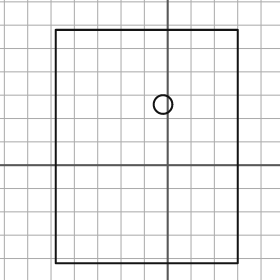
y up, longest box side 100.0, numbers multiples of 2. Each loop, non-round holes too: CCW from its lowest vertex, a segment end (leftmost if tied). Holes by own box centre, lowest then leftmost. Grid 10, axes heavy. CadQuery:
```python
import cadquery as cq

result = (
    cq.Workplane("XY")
    .moveTo(-48.0, -42.0)
    .lineTo(30.0, -42.0)
    .lineTo(30.0, 58.0)
    .lineTo(-48.0, 58.0)
    .close()
    .moveTo(-2.0, 26.0)
    .circle(4.0)
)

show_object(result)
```